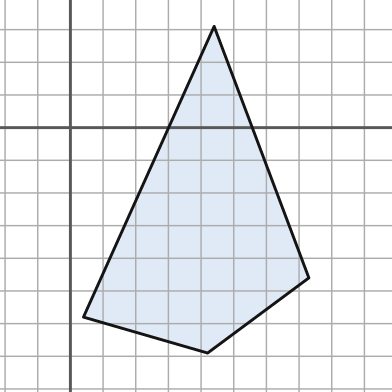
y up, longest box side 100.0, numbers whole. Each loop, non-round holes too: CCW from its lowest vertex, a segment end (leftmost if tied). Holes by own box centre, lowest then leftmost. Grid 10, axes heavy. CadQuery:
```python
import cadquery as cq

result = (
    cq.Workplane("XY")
    .moveTo(42.0, -69.0)
    .lineTo(73.0, -46.0)
    .lineTo(44.0, 31.0)
    .lineTo(4.0, -58.0)
    .close()
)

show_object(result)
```